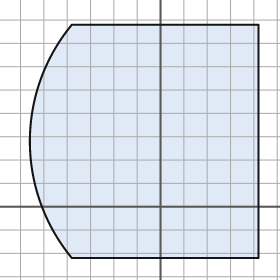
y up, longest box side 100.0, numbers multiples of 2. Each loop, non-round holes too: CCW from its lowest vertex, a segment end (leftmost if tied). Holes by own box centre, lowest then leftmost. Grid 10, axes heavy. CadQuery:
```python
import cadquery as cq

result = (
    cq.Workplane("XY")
    .moveTo(-38.0, -22.0)
    .lineTo(42.0, -22.0)
    .lineTo(42.0, 78.0)
    .lineTo(-38.0, 78.0)
    .threePointArc((-56.0, 28.0), (-38.0, -22.0))
    .close()
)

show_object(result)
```